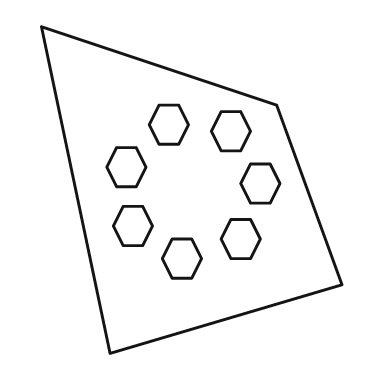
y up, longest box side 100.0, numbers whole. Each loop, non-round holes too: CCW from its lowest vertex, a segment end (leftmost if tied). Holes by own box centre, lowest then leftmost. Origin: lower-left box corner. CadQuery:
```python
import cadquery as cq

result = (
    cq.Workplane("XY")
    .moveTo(21.0, 0.0)
    .lineTo(92.0, 21.0)
    .lineTo(72.0, 76.0)
    .lineTo(0.0, 100.0)
    .close()
    .moveTo(40.0, 23.0)
    .lineTo(46.0, 23.0)
    .lineTo(49.0, 29.0)
    .lineTo(46.0, 35.0)
    .lineTo(40.0, 35.0)
    .lineTo(37.0, 29.0)
    .close()
    .moveTo(58.0, 29.0)
    .lineTo(64.0, 29.0)
    .lineTo(67.0, 35.0)
    .lineTo(64.0, 41.0)
    .lineTo(58.0, 41.0)
    .lineTo(55.0, 35.0)
    .close()
    .moveTo(25.0, 33.0)
    .lineTo(31.0, 33.0)
    .lineTo(34.0, 39.0)
    .lineTo(31.0, 45.0)
    .lineTo(25.0, 45.0)
    .lineTo(22.0, 39.0)
    .close()
    .moveTo(64.0, 46.0)
    .lineTo(70.0, 46.0)
    .lineTo(73.0, 52.0)
    .lineTo(70.0, 58.0)
    .lineTo(64.0, 58.0)
    .lineTo(61.0, 52.0)
    .close()
    .moveTo(23.0, 51.0)
    .lineTo(29.0, 51.0)
    .lineTo(32.0, 57.0)
    .lineTo(29.0, 63.0)
    .lineTo(23.0, 63.0)
    .lineTo(20.0, 57.0)
    .close()
    .moveTo(55.0, 62.0)
    .lineTo(61.0, 62.0)
    .lineTo(64.0, 68.0)
    .lineTo(61.0, 74.0)
    .lineTo(55.0, 74.0)
    .lineTo(52.0, 68.0)
    .close()
    .moveTo(36.0, 64.0)
    .lineTo(42.0, 64.0)
    .lineTo(45.0, 70.0)
    .lineTo(42.0, 76.0)
    .lineTo(36.0, 76.0)
    .lineTo(33.0, 70.0)
    .close()
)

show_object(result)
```